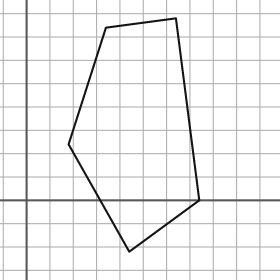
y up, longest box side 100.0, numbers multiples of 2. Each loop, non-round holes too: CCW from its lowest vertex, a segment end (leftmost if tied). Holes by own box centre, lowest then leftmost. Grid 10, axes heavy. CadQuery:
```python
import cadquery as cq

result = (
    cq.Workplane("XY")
    .moveTo(44.0, -22.0)
    .lineTo(74.0, 0.0)
    .lineTo(64.0, 78.0)
    .lineTo(34.0, 74.0)
    .lineTo(18.0, 24.0)
    .close()
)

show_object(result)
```